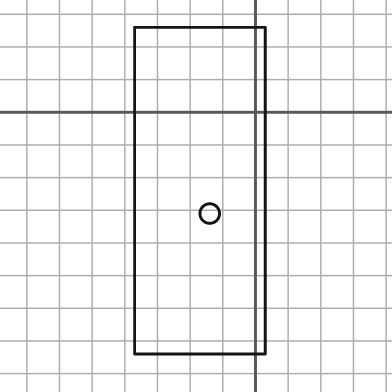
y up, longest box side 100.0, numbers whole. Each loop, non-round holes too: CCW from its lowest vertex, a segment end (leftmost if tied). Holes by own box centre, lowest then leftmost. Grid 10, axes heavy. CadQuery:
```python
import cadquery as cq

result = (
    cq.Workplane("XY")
    .moveTo(-37.0, -74.0)
    .lineTo(3.0, -74.0)
    .lineTo(3.0, 26.0)
    .lineTo(-37.0, 26.0)
    .close()
    .moveTo(-14.0, -31.0)
    .circle(3.0)
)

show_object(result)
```